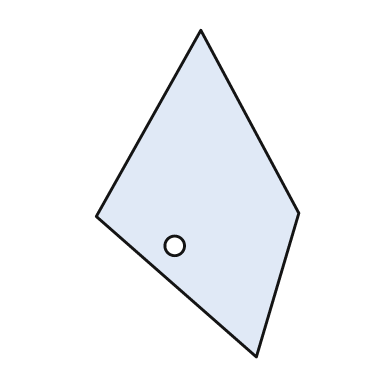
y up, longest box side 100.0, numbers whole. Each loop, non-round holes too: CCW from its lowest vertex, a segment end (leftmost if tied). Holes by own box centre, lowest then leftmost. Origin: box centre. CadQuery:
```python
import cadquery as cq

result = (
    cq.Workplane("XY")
    .moveTo(18.0, -50.0)
    .lineTo(31.0, -6.0)
    .lineTo(1.0, 50.0)
    .lineTo(-31.0, -7.0)
    .close()
    .moveTo(-7.0, -16.0)
    .circle(3.0)
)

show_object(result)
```